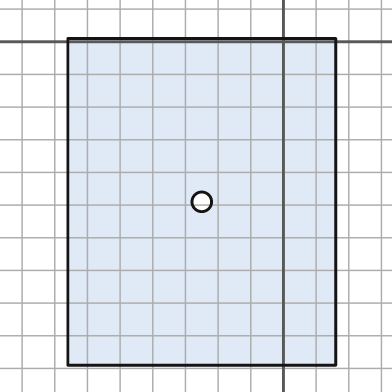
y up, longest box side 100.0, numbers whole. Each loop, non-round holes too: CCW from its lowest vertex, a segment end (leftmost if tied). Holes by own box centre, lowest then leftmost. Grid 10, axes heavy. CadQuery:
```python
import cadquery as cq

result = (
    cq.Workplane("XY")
    .moveTo(-66.0, -99.0)
    .lineTo(16.0, -99.0)
    .lineTo(16.0, 1.0)
    .lineTo(-66.0, 1.0)
    .close()
    .moveTo(-25.0, -49.0)
    .circle(3.0)
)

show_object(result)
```